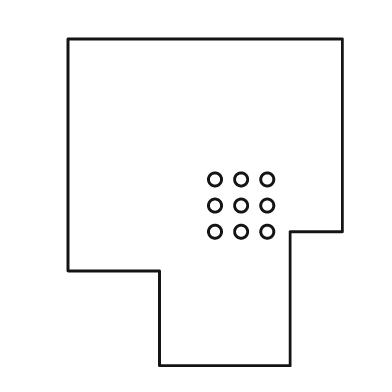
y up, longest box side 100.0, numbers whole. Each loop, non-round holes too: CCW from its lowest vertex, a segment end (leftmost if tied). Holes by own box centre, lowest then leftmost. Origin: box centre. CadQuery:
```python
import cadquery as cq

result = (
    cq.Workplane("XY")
    .moveTo(-14.0, -50.0)
    .lineTo(26.0, -50.0)
    .lineTo(26.0, -9.0)
    .lineTo(42.0, -9.0)
    .lineTo(42.0, 50.0)
    .lineTo(-42.0, 50.0)
    .lineTo(-42.0, -21.0)
    .lineTo(-14.0, -21.0)
    .close()
    .moveTo(3.0, -9.0)
    .circle(2.0)
    .moveTo(11.0, -9.0)
    .circle(2.0)
    .moveTo(19.0, -9.0)
    .circle(2.0)
    .moveTo(3.0, -1.0)
    .circle(2.0)
    .moveTo(11.0, -1.0)
    .circle(2.0)
    .moveTo(19.0, -1.0)
    .circle(2.0)
    .moveTo(3.0, 7.0)
    .circle(2.0)
    .moveTo(11.0, 7.0)
    .circle(2.0)
    .moveTo(19.0, 7.0)
    .circle(2.0)
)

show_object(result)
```